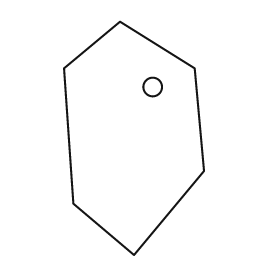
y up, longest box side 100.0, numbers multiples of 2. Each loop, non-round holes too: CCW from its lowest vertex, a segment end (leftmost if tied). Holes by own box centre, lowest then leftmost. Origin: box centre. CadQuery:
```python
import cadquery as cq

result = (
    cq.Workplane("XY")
    .moveTo(0.0, -50.0)
    .lineTo(30.0, -14.0)
    .lineTo(26.0, 30.0)
    .lineTo(-6.0, 50.0)
    .lineTo(-30.0, 30.0)
    .lineTo(-26.0, -28.0)
    .close()
    .moveTo(8.0, 22.0)
    .circle(4.0)
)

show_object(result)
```